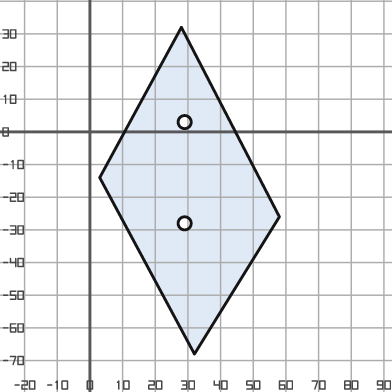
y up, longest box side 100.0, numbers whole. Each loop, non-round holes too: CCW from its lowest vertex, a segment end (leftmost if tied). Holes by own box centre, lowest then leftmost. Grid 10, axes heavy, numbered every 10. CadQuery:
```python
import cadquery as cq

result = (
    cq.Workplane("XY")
    .moveTo(32.0, -68.0)
    .lineTo(58.0, -26.0)
    .lineTo(28.0, 32.0)
    .lineTo(3.0, -14.0)
    .close()
    .moveTo(29.0, -28.0)
    .circle(2.0)
    .moveTo(29.0, 3.0)
    .circle(2.0)
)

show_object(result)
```